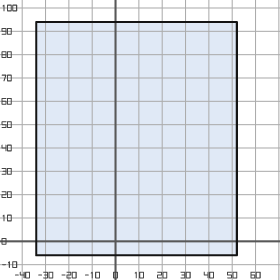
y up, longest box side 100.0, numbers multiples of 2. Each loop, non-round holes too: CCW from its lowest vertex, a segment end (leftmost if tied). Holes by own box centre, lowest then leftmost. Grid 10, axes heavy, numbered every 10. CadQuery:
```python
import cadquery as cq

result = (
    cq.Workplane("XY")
    .moveTo(-34.0, -6.0)
    .lineTo(52.0, -6.0)
    .lineTo(52.0, 94.0)
    .lineTo(-34.0, 94.0)
    .close()
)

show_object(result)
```